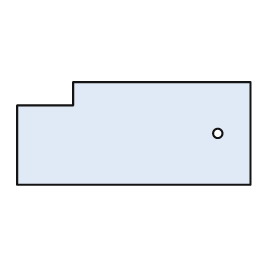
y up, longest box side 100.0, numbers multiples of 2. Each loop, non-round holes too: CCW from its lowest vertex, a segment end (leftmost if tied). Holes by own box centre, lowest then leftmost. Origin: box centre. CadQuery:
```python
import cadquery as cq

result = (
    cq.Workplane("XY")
    .moveTo(-50.0, -22.0)
    .lineTo(50.0, -22.0)
    .lineTo(50.0, 22.0)
    .lineTo(-26.0, 22.0)
    .lineTo(-26.0, 12.0)
    .lineTo(-50.0, 12.0)
    .close()
    .moveTo(36.0, 0.0)
    .circle(2.0)
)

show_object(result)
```